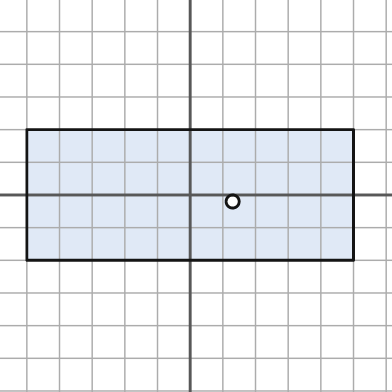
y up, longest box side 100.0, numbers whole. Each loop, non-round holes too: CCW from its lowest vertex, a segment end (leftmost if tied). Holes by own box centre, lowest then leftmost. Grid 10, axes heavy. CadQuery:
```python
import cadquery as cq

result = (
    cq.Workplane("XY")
    .moveTo(-50.0, -20.0)
    .lineTo(50.0, -20.0)
    .lineTo(50.0, 20.0)
    .lineTo(-50.0, 20.0)
    .close()
    .moveTo(13.0, -2.0)
    .circle(2.0)
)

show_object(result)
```